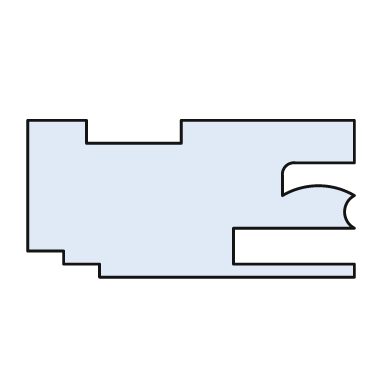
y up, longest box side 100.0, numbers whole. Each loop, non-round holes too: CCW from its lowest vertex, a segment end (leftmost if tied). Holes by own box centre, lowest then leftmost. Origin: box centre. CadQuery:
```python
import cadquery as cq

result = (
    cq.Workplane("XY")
    .moveTo(-28.0, -24.0)
    .lineTo(50.0, -24.0)
    .lineTo(50.0, -20.0)
    .lineTo(13.0, -20.0)
    .lineTo(13.0, -9.0)
    .lineTo(50.0, -9.0)
    .threePointArc((47.0, -4.0), (50.0, 1.0))
    .threePointArc((39.0, 4.0), (28.0, 1.0))
    .lineTo(28.0, 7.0)
    .threePointArc((29.0, 10.0), (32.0, 11.0))
    .lineTo(50.0, 11.0)
    .lineTo(50.0, 24.0)
    .lineTo(-3.0, 24.0)
    .lineTo(-3.0, 17.0)
    .lineTo(-32.0, 17.0)
    .lineTo(-32.0, 24.0)
    .lineTo(-50.0, 24.0)
    .lineTo(-50.0, -16.0)
    .lineTo(-39.0, -16.0)
    .lineTo(-39.0, -20.0)
    .lineTo(-28.0, -20.0)
    .close()
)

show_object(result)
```